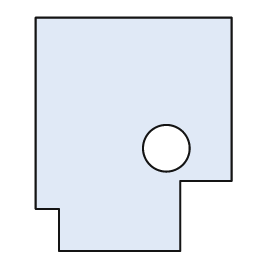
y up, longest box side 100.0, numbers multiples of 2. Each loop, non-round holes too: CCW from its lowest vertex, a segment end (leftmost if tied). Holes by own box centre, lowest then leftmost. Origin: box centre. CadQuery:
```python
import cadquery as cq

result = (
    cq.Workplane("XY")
    .moveTo(-32.0, -50.0)
    .lineTo(20.0, -50.0)
    .lineTo(20.0, -20.0)
    .lineTo(42.0, -20.0)
    .lineTo(42.0, 50.0)
    .lineTo(-42.0, 50.0)
    .lineTo(-42.0, -32.0)
    .lineTo(-32.0, -32.0)
    .close()
    .moveTo(14.0, -6.0)
    .circle(10.0)
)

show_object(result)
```